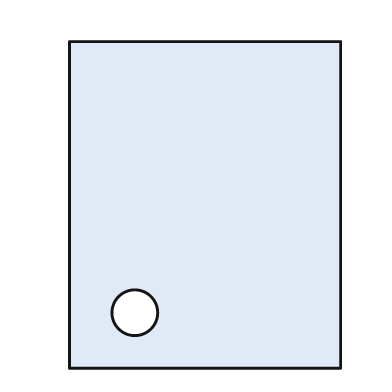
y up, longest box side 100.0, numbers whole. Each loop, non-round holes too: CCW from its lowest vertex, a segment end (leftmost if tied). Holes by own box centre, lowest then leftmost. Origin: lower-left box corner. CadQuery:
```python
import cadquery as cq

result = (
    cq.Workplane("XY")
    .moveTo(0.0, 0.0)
    .lineTo(83.0, 0.0)
    .lineTo(83.0, 100.0)
    .lineTo(0.0, 100.0)
    .close()
    .moveTo(20.0, 17.0)
    .circle(7.0)
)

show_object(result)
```